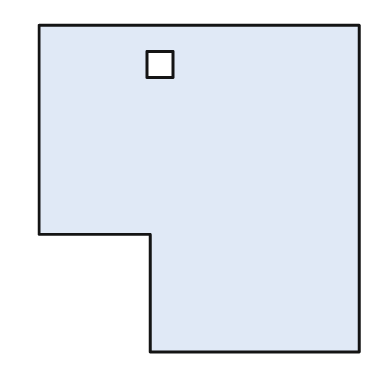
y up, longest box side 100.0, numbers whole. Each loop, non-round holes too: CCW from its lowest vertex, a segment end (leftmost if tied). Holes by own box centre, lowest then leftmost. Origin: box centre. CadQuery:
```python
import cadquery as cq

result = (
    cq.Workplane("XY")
    .moveTo(-15.0, -50.0)
    .lineTo(49.0, -50.0)
    .lineTo(49.0, 50.0)
    .lineTo(-49.0, 50.0)
    .lineTo(-49.0, -14.0)
    .lineTo(-15.0, -14.0)
    .close()
    .moveTo(-16.0, 34.0)
    .lineTo(-8.0, 34.0)
    .lineTo(-8.0, 42.0)
    .lineTo(-16.0, 42.0)
    .close()
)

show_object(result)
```